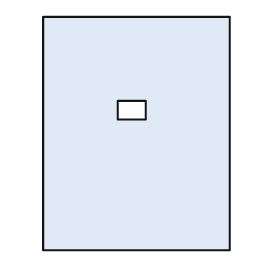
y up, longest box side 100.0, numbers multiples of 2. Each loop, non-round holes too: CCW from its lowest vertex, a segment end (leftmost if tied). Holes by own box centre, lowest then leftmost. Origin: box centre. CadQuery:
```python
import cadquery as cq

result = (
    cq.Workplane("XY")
    .moveTo(-40.0, -50.0)
    .lineTo(40.0, -50.0)
    .lineTo(40.0, 50.0)
    .lineTo(-40.0, 50.0)
    .close()
    .moveTo(-8.0, 6.0)
    .lineTo(4.0, 6.0)
    .lineTo(4.0, 14.0)
    .lineTo(-8.0, 14.0)
    .close()
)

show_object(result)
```